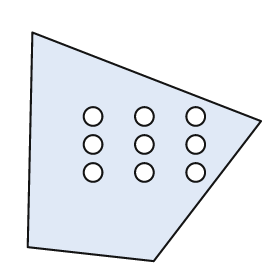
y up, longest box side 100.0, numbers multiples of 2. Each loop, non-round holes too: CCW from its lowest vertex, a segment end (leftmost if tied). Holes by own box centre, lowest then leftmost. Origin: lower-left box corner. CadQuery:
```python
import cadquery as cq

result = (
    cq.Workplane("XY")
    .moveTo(54.0, 0.0)
    .lineTo(100.0, 60.0)
    .lineTo(2.0, 98.0)
    .lineTo(0.0, 6.0)
    .close()
    .moveTo(28.0, 38.0)
    .circle(4.0)
    .moveTo(50.0, 38.0)
    .circle(4.0)
    .moveTo(72.0, 38.0)
    .circle(4.0)
    .moveTo(28.0, 50.0)
    .circle(4.0)
    .moveTo(50.0, 50.0)
    .circle(4.0)
    .moveTo(72.0, 50.0)
    .circle(4.0)
    .moveTo(28.0, 62.0)
    .circle(4.0)
    .moveTo(50.0, 62.0)
    .circle(4.0)
    .moveTo(72.0, 62.0)
    .circle(4.0)
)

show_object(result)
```